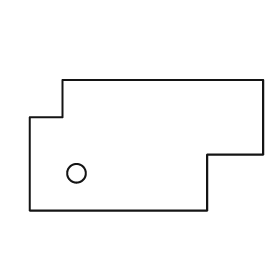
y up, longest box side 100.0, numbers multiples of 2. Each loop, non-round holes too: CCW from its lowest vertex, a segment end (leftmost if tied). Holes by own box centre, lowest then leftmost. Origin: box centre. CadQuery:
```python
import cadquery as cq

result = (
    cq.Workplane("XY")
    .moveTo(-50.0, -28.0)
    .lineTo(26.0, -28.0)
    .lineTo(26.0, -4.0)
    .lineTo(50.0, -4.0)
    .lineTo(50.0, 28.0)
    .lineTo(-36.0, 28.0)
    .lineTo(-36.0, 12.0)
    .lineTo(-50.0, 12.0)
    .close()
    .moveTo(-30.0, -12.0)
    .circle(4.0)
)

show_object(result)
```